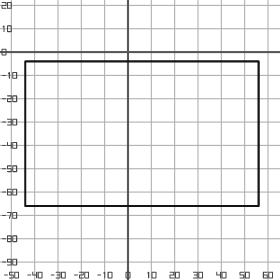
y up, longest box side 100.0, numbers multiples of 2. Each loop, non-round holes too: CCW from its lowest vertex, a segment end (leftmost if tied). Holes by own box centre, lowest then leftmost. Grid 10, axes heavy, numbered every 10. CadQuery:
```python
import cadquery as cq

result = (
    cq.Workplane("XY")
    .moveTo(-44.0, -66.0)
    .lineTo(56.0, -66.0)
    .lineTo(56.0, -4.0)
    .lineTo(-44.0, -4.0)
    .close()
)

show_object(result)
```